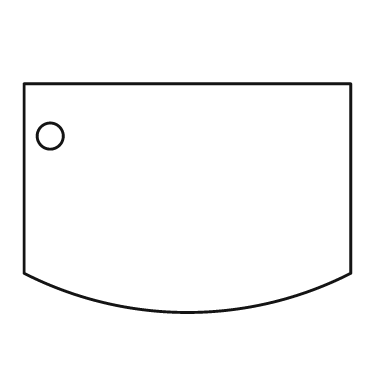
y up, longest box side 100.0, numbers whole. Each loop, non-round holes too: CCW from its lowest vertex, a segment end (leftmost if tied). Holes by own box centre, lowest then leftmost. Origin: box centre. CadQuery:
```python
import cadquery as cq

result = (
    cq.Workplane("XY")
    .moveTo(-50.0, -23.0)
    .threePointArc((0.0, -35.0), (50.0, -23.0))
    .lineTo(50.0, 35.0)
    .lineTo(-50.0, 35.0)
    .close()
    .moveTo(-42.0, 19.0)
    .circle(4.0)
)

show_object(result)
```